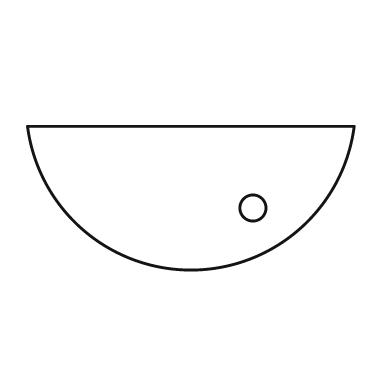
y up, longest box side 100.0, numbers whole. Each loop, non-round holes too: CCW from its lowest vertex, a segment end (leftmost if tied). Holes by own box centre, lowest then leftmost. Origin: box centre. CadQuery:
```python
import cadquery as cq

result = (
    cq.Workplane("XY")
    .moveTo(-50.0, 22.0)
    .threePointArc((0.0, -22.0), (50.0, 22.0))
    .close()
    .moveTo(19.0, -3.0)
    .circle(4.0)
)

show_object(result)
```